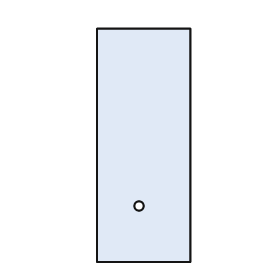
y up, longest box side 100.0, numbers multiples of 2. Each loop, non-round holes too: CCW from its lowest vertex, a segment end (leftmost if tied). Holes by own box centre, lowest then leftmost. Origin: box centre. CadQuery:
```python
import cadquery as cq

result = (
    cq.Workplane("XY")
    .moveTo(-20.0, -50.0)
    .lineTo(20.0, -50.0)
    .lineTo(20.0, 50.0)
    .lineTo(-20.0, 50.0)
    .close()
    .moveTo(-2.0, -26.0)
    .circle(2.0)
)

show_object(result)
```